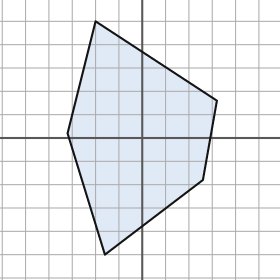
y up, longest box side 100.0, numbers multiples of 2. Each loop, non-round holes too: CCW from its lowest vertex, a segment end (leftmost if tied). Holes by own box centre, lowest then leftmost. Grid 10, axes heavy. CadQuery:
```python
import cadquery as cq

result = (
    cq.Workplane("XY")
    .moveTo(-16.0, -50.0)
    .lineTo(26.0, -18.0)
    .lineTo(32.0, 16.0)
    .lineTo(-20.0, 50.0)
    .lineTo(-32.0, 2.0)
    .close()
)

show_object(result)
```